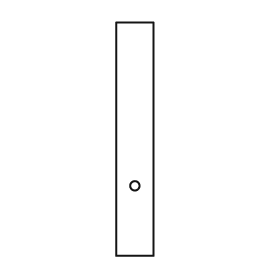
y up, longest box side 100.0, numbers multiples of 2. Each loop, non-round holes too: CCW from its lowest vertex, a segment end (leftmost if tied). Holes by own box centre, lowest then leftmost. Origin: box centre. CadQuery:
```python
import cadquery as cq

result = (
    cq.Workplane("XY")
    .moveTo(-8.0, -50.0)
    .lineTo(8.0, -50.0)
    .lineTo(8.0, 50.0)
    .lineTo(-8.0, 50.0)
    .close()
    .moveTo(0.0, -20.0)
    .circle(2.0)
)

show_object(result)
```